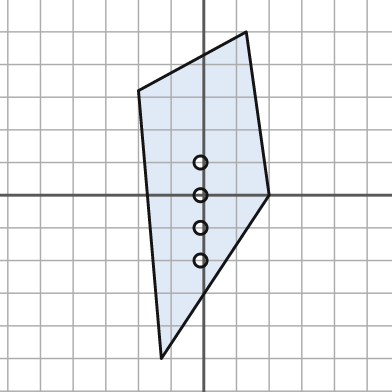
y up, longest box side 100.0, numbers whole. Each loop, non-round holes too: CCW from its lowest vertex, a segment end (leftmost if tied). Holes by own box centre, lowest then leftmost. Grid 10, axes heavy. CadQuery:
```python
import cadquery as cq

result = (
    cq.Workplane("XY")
    .moveTo(-13.0, -50.0)
    .lineTo(20.0, 0.0)
    .lineTo(13.0, 50.0)
    .lineTo(-20.0, 32.0)
    .close()
    .moveTo(-1.0, -20.0)
    .circle(2.0)
    .moveTo(-1.0, -10.0)
    .circle(2.0)
    .moveTo(-1.0, 0.0)
    .circle(2.0)
    .moveTo(-1.0, 10.0)
    .circle(2.0)
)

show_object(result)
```